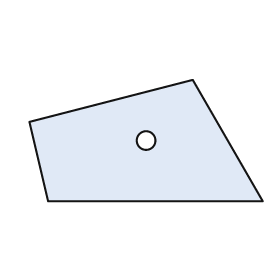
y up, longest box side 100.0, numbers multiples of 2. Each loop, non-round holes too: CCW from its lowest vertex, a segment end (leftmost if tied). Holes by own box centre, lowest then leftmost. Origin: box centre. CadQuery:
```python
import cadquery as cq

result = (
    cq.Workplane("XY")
    .moveTo(-42.0, -26.0)
    .lineTo(50.0, -26.0)
    .lineTo(20.0, 26.0)
    .lineTo(-50.0, 8.0)
    .close()
    .moveTo(0.0, 0.0)
    .circle(4.0)
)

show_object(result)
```